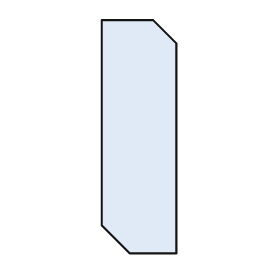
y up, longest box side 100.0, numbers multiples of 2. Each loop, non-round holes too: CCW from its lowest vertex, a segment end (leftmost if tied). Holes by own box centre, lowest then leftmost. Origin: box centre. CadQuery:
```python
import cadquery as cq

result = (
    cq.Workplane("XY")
    .moveTo(-4.0, -50.0)
    .lineTo(16.0, -50.0)
    .lineTo(16.0, 40.0)
    .lineTo(6.0, 50.0)
    .lineTo(-16.0, 50.0)
    .lineTo(-16.0, -38.0)
    .close()
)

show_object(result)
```